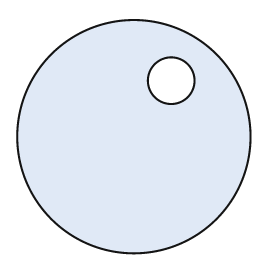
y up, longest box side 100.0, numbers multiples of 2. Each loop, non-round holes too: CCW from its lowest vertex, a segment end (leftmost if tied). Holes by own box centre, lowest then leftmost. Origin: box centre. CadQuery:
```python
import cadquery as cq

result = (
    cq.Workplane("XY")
    .moveTo(0.0, 0.0)
    .circle(50.0)
    .moveTo(16.0, 24.0)
    .circle(10.0)
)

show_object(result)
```